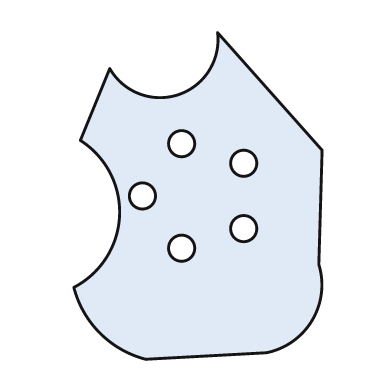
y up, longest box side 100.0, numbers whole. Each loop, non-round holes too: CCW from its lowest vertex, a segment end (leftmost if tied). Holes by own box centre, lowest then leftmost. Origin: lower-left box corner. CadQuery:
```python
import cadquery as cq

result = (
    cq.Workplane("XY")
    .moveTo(22.0, 0.0)
    .lineTo(59.0, 2.0)
    .threePointArc((73.0, 12.0), (75.0, 29.0))
    .lineTo(76.0, 64.0)
    .lineTo(44.0, 100.0)
    .threePointArc((32.0, 81.0), (11.0, 89.0))
    .lineTo(2.0, 67.0)
    .threePointArc((14.0, 44.0), (0.0, 22.0))
    .threePointArc((8.0, 8.0), (22.0, 0.0))
    .close()
    .moveTo(33.0, 34.0)
    .circle(4.0)
    .moveTo(52.0, 40.0)
    .circle(4.0)
    .moveTo(21.0, 50.0)
    .circle(4.0)
    .moveTo(52.0, 60.0)
    .circle(4.0)
    .moveTo(33.0, 66.0)
    .circle(4.0)
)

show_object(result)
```